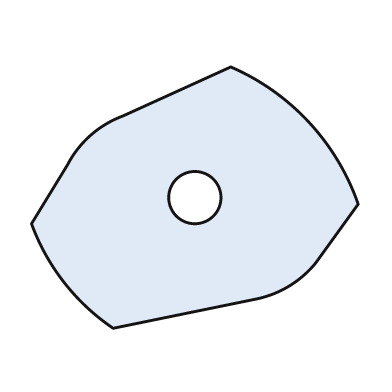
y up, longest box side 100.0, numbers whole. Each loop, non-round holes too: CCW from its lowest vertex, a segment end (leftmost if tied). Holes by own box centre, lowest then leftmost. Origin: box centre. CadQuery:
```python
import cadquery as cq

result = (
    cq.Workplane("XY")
    .moveTo(-25.0, -40.0)
    .lineTo(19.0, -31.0)
    .threePointArc((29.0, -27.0), (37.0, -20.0))
    .lineTo(50.0, -2.0)
    .threePointArc((35.0, 23.0), (11.0, 40.0))
    .lineTo(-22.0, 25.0)
    .threePointArc((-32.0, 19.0), (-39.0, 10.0))
    .lineTo(-50.0, -8.0)
    .threePointArc((-40.0, -26.0), (-25.0, -40.0))
    .close()
    .moveTo(0.0, 0.0)
    .circle(8.0)
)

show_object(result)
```